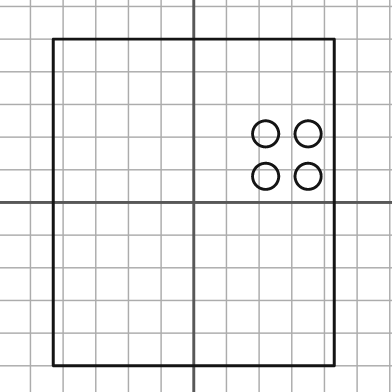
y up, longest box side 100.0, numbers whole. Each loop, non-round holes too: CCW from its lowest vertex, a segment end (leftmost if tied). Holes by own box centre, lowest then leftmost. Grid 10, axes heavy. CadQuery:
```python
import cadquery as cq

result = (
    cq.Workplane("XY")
    .moveTo(-43.0, -50.0)
    .lineTo(43.0, -50.0)
    .lineTo(43.0, 50.0)
    .lineTo(-43.0, 50.0)
    .close()
    .moveTo(22.0, 8.0)
    .circle(4.0)
    .moveTo(35.0, 8.0)
    .circle(4.0)
    .moveTo(22.0, 21.0)
    .circle(4.0)
    .moveTo(35.0, 21.0)
    .circle(4.0)
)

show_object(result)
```